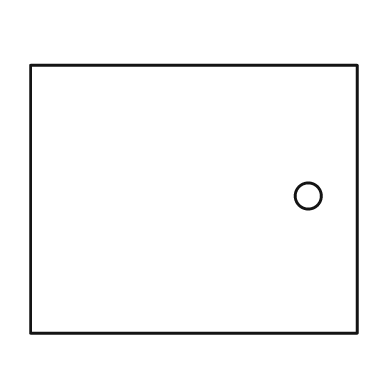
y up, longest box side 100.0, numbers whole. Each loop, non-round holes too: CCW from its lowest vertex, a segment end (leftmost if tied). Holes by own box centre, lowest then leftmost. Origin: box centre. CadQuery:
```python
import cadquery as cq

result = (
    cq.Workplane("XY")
    .moveTo(-50.0, -41.0)
    .lineTo(50.0, -41.0)
    .lineTo(50.0, 41.0)
    .lineTo(-50.0, 41.0)
    .close()
    .moveTo(35.0, 1.0)
    .circle(4.0)
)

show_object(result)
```